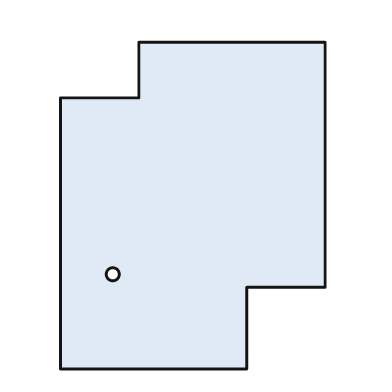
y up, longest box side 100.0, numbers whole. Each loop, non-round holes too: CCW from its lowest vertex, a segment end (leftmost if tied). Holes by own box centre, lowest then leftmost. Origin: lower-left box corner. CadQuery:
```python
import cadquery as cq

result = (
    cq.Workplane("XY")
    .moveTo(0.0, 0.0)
    .lineTo(57.0, 0.0)
    .lineTo(57.0, 25.0)
    .lineTo(81.0, 25.0)
    .lineTo(81.0, 100.0)
    .lineTo(24.0, 100.0)
    .lineTo(24.0, 83.0)
    .lineTo(0.0, 83.0)
    .close()
    .moveTo(16.0, 29.0)
    .circle(2.0)
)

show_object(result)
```